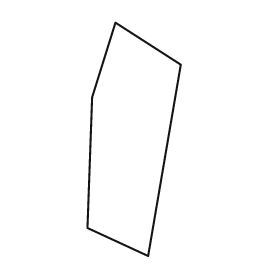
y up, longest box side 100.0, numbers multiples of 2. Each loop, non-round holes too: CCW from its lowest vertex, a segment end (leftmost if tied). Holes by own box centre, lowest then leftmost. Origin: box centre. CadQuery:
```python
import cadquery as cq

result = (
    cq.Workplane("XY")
    .moveTo(6.0, -50.0)
    .lineTo(20.0, 32.0)
    .lineTo(-8.0, 50.0)
    .lineTo(-18.0, 18.0)
    .lineTo(-20.0, -38.0)
    .close()
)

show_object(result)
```